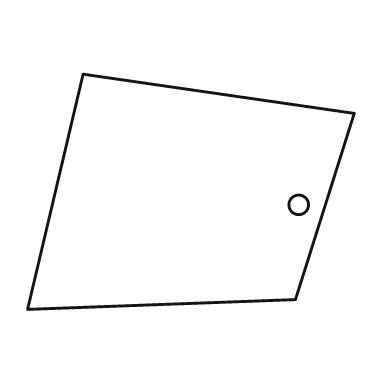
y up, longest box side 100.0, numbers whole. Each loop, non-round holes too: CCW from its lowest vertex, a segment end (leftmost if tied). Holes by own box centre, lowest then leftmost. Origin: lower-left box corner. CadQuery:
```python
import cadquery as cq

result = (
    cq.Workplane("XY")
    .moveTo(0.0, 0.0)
    .lineTo(82.0, 3.0)
    .lineTo(100.0, 60.0)
    .lineTo(17.0, 72.0)
    .close()
    .moveTo(83.0, 32.0)
    .circle(3.0)
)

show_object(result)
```